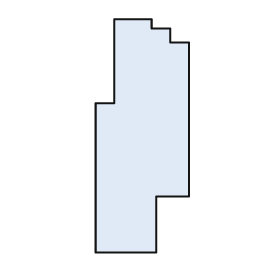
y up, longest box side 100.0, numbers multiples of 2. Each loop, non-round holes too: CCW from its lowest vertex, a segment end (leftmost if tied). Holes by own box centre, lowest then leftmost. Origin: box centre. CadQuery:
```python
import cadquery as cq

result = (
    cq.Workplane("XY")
    .moveTo(-20.0, -50.0)
    .lineTo(6.0, -50.0)
    .lineTo(6.0, -26.0)
    .lineTo(20.0, -26.0)
    .lineTo(20.0, 40.0)
    .lineTo(12.0, 40.0)
    .lineTo(12.0, 46.0)
    .lineTo(4.0, 46.0)
    .lineTo(4.0, 50.0)
    .lineTo(-12.0, 50.0)
    .lineTo(-12.0, 14.0)
    .lineTo(-20.0, 14.0)
    .close()
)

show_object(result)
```